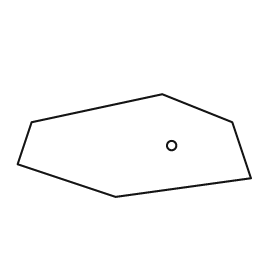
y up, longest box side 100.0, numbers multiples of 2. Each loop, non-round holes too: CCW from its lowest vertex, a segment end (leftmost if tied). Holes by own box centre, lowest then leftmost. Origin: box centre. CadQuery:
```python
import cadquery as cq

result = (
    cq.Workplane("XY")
    .moveTo(-8.0, -22.0)
    .lineTo(50.0, -14.0)
    .lineTo(42.0, 10.0)
    .lineTo(12.0, 22.0)
    .lineTo(-44.0, 10.0)
    .lineTo(-50.0, -8.0)
    .close()
    .moveTo(16.0, 0.0)
    .circle(2.0)
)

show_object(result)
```